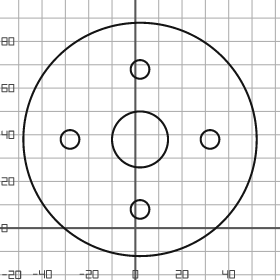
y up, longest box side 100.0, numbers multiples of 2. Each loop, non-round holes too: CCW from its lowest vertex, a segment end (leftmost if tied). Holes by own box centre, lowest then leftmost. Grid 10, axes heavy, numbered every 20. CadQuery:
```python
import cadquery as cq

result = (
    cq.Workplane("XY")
    .moveTo(2.0, 38.0)
    .circle(50.0)
    .moveTo(2.0, 8.0)
    .circle(4.0)
    .moveTo(-28.0, 38.0)
    .circle(4.0)
    .moveTo(2.0, 38.0)
    .circle(12.0)
    .moveTo(32.0, 38.0)
    .circle(4.0)
    .moveTo(2.0, 68.0)
    .circle(4.0)
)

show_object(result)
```